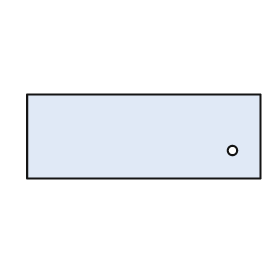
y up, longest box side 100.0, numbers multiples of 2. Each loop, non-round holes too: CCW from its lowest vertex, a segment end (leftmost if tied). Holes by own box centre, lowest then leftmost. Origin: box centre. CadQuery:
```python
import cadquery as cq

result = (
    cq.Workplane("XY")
    .moveTo(-50.0, -18.0)
    .lineTo(50.0, -18.0)
    .lineTo(50.0, 18.0)
    .lineTo(-50.0, 18.0)
    .close()
    .moveTo(38.0, -6.0)
    .circle(2.0)
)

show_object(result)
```